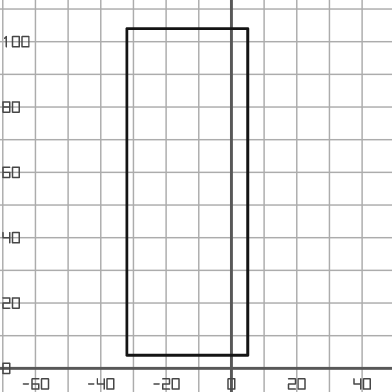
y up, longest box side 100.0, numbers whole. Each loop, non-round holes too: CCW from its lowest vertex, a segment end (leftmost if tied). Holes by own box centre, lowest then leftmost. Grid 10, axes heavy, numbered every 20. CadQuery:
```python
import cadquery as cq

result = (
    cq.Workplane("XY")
    .moveTo(-32.0, 4.0)
    .lineTo(5.0, 4.0)
    .lineTo(5.0, 104.0)
    .lineTo(-32.0, 104.0)
    .close()
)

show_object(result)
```